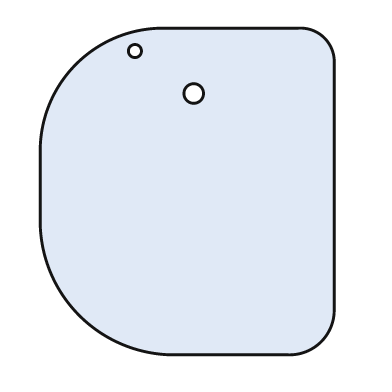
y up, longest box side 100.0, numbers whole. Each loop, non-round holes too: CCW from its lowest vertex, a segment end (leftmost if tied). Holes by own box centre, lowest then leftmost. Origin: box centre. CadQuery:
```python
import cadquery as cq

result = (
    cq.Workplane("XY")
    .moveTo(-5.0, -50.0)
    .lineTo(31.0, -50.0)
    .threePointArc((41.0, -46.0), (45.0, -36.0))
    .lineTo(45.0, 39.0)
    .threePointArc((42.0, 47.0), (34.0, 50.0))
    .lineTo(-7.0, 50.0)
    .threePointArc((-34.0, 39.0), (-45.0, 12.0))
    .lineTo(-45.0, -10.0)
    .threePointArc((-33.0, -38.0), (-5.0, -50.0))
    .close()
    .moveTo(2.0, 30.0)
    .circle(3.0)
    .moveTo(-16.0, 43.0)
    .circle(2.0)
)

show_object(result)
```